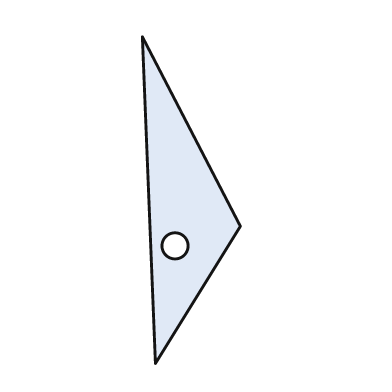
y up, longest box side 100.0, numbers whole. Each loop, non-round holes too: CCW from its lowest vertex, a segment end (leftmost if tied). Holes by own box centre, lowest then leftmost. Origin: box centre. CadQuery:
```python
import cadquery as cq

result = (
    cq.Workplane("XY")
    .moveTo(-11.0, -50.0)
    .lineTo(15.0, -8.0)
    .lineTo(-15.0, 50.0)
    .close()
    .moveTo(-5.0, -14.0)
    .circle(4.0)
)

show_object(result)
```